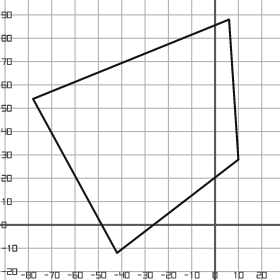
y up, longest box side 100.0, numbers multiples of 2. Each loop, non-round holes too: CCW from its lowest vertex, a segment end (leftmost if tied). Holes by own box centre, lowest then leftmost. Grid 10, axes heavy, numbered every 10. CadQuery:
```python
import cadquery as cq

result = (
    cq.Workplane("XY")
    .moveTo(-42.0, -12.0)
    .lineTo(10.0, 28.0)
    .lineTo(6.0, 88.0)
    .lineTo(-78.0, 54.0)
    .close()
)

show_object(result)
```